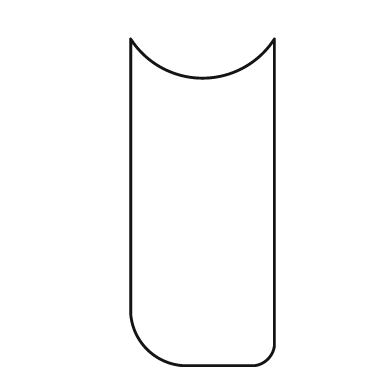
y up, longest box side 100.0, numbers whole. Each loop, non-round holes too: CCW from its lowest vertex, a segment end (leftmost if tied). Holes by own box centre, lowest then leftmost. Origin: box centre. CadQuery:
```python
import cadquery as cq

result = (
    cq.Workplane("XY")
    .moveTo(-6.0, -50.0)
    .lineTo(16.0, -50.0)
    .threePointArc((20.0, -48.0), (22.0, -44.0))
    .lineTo(22.0, 50.0)
    .threePointArc((0.0, 38.0), (-22.0, 50.0))
    .lineTo(-22.0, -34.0)
    .threePointArc((-17.0, -45.0), (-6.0, -50.0))
    .close()
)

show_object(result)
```